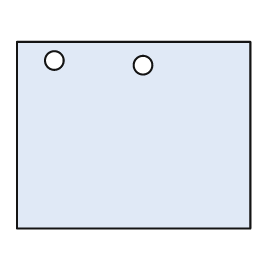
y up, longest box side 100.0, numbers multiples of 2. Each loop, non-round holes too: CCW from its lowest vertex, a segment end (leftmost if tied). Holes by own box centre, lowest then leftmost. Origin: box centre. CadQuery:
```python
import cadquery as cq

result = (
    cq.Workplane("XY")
    .moveTo(-50.0, -40.0)
    .lineTo(50.0, -40.0)
    .lineTo(50.0, 40.0)
    .lineTo(-50.0, 40.0)
    .close()
    .moveTo(4.0, 30.0)
    .circle(4.0)
    .moveTo(-34.0, 32.0)
    .circle(4.0)
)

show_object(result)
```